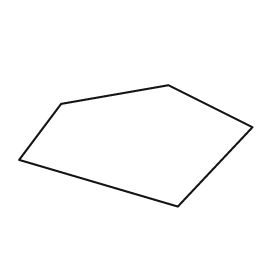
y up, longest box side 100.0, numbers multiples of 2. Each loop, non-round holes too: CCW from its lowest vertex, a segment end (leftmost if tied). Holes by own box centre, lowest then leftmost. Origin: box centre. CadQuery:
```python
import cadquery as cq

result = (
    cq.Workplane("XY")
    .moveTo(18.0, -26.0)
    .lineTo(50.0, 8.0)
    .lineTo(14.0, 26.0)
    .lineTo(-32.0, 18.0)
    .lineTo(-50.0, -6.0)
    .close()
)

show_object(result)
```